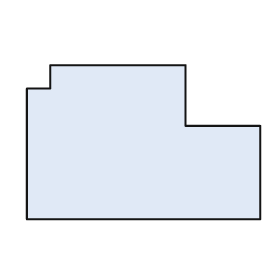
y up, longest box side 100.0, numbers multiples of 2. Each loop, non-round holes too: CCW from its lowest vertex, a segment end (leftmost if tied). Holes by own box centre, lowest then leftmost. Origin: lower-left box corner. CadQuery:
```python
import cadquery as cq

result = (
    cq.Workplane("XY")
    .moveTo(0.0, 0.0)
    .lineTo(100.0, 0.0)
    .lineTo(100.0, 40.0)
    .lineTo(68.0, 40.0)
    .lineTo(68.0, 66.0)
    .lineTo(10.0, 66.0)
    .lineTo(10.0, 56.0)
    .lineTo(0.0, 56.0)
    .close()
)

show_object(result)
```